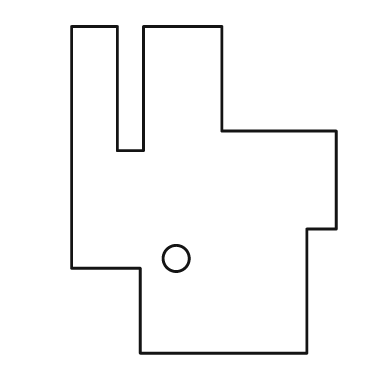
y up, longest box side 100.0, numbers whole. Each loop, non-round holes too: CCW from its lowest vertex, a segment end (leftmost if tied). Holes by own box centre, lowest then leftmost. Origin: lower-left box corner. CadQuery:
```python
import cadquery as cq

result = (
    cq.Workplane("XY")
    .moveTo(21.0, 0.0)
    .lineTo(72.0, 0.0)
    .lineTo(72.0, 38.0)
    .lineTo(81.0, 38.0)
    .lineTo(81.0, 68.0)
    .lineTo(46.0, 68.0)
    .lineTo(46.0, 100.0)
    .lineTo(22.0, 100.0)
    .lineTo(22.0, 62.0)
    .lineTo(14.0, 62.0)
    .lineTo(14.0, 100.0)
    .lineTo(0.0, 100.0)
    .lineTo(0.0, 26.0)
    .lineTo(21.0, 26.0)
    .close()
    .moveTo(32.0, 29.0)
    .circle(4.0)
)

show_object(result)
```